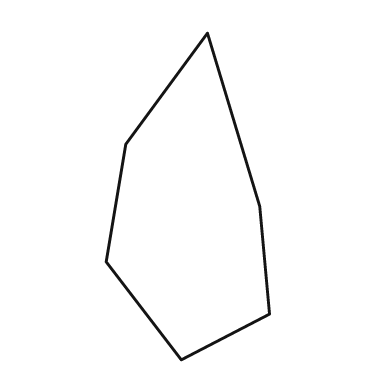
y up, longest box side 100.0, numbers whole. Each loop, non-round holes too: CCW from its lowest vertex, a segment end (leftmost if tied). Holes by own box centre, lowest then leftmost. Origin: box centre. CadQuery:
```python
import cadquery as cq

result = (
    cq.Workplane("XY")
    .moveTo(-2.0, -50.0)
    .lineTo(25.0, -36.0)
    .lineTo(22.0, -3.0)
    .lineTo(6.0, 50.0)
    .lineTo(-19.0, 16.0)
    .lineTo(-25.0, -20.0)
    .close()
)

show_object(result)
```